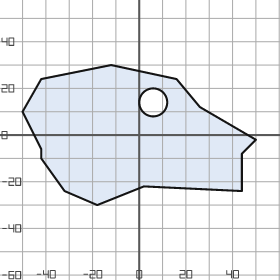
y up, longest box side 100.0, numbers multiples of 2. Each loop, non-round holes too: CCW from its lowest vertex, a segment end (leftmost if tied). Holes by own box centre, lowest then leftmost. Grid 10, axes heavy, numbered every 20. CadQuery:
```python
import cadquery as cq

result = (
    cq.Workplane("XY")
    .moveTo(-18.0, -30.0)
    .lineTo(2.0, -22.0)
    .lineTo(44.0, -24.0)
    .lineTo(44.0, -8.0)
    .lineTo(50.0, -2.0)
    .lineTo(26.0, 12.0)
    .lineTo(16.0, 24.0)
    .lineTo(-12.0, 30.0)
    .lineTo(-42.0, 24.0)
    .lineTo(-50.0, 10.0)
    .lineTo(-42.0, -6.0)
    .lineTo(-42.0, -10.0)
    .lineTo(-32.0, -24.0)
    .close()
    .moveTo(6.0, 14.0)
    .circle(6.0)
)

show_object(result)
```